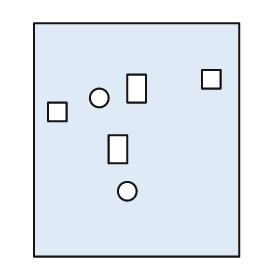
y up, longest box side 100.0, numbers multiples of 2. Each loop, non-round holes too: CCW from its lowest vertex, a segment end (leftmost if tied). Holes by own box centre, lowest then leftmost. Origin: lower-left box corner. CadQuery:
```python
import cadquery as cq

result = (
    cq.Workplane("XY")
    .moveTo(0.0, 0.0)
    .lineTo(88.0, 0.0)
    .lineTo(88.0, 100.0)
    .lineTo(0.0, 100.0)
    .close()
    .moveTo(40.0, 28.0)
    .circle(4.0)
    .moveTo(32.0, 40.0)
    .lineTo(40.0, 40.0)
    .lineTo(40.0, 52.0)
    .lineTo(32.0, 52.0)
    .close()
    .moveTo(6.0, 58.0)
    .lineTo(14.0, 58.0)
    .lineTo(14.0, 66.0)
    .lineTo(6.0, 66.0)
    .close()
    .moveTo(28.0, 68.0)
    .circle(4.0)
    .moveTo(40.0, 66.0)
    .lineTo(48.0, 66.0)
    .lineTo(48.0, 78.0)
    .lineTo(40.0, 78.0)
    .close()
    .moveTo(72.0, 72.0)
    .lineTo(80.0, 72.0)
    .lineTo(80.0, 80.0)
    .lineTo(72.0, 80.0)
    .close()
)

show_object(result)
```